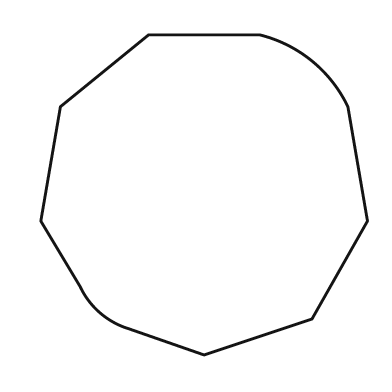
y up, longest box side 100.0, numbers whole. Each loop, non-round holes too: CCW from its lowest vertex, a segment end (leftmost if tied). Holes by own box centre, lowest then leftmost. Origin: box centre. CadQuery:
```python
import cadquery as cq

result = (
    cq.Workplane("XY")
    .moveTo(0.0, -49.0)
    .lineTo(33.0, -38.0)
    .lineTo(50.0, -8.0)
    .lineTo(44.0, 27.0)
    .threePointArc((33.0, 41.0), (17.0, 49.0))
    .lineTo(-17.0, 49.0)
    .lineTo(-44.0, 27.0)
    .lineTo(-50.0, -8.0)
    .lineTo(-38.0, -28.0)
    .threePointArc((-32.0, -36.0), (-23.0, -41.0))
    .close()
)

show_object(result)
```